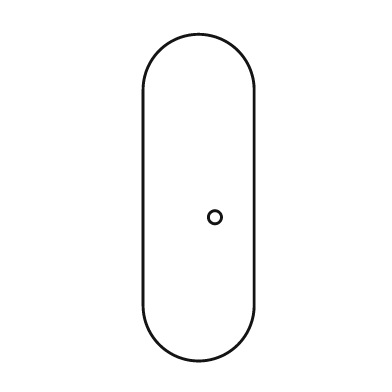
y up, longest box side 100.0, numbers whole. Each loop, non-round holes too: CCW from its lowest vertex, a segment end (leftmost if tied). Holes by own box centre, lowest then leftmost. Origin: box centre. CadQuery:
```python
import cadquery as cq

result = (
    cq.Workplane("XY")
    .moveTo(-17.0, -33.0)
    .threePointArc((0.0, -50.0), (17.0, -33.0))
    .lineTo(17.0, 33.0)
    .threePointArc((0.0, 50.0), (-17.0, 33.0))
    .close()
    .moveTo(5.0, -6.0)
    .circle(2.0)
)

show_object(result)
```